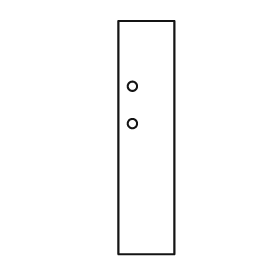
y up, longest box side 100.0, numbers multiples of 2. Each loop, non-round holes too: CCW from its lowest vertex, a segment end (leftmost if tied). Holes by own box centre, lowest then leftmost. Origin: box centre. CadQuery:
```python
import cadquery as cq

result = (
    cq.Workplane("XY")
    .moveTo(-12.0, -50.0)
    .lineTo(12.0, -50.0)
    .lineTo(12.0, 50.0)
    .lineTo(-12.0, 50.0)
    .close()
    .moveTo(-6.0, 6.0)
    .circle(2.0)
    .moveTo(-6.0, 22.0)
    .circle(2.0)
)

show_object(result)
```